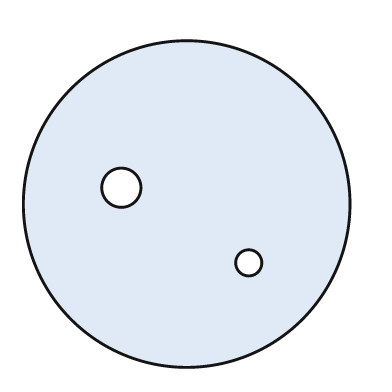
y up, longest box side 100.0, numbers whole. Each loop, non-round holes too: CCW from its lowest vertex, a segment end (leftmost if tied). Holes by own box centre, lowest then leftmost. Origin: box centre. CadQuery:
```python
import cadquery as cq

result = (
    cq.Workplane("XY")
    .moveTo(0.0, 0.0)
    .circle(50.0)
    .moveTo(19.0, -18.0)
    .circle(4.0)
    .moveTo(-20.0, 5.0)
    .circle(6.0)
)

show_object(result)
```